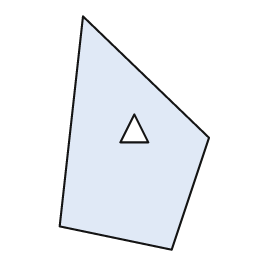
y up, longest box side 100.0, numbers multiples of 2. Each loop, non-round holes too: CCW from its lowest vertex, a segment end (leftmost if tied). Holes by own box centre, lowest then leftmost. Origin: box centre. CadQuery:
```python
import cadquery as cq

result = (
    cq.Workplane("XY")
    .moveTo(16.0, -50.0)
    .lineTo(32.0, -2.0)
    .lineTo(-22.0, 50.0)
    .lineTo(-32.0, -40.0)
    .close()
    .moveTo(-6.0, -4.0)
    .lineTo(6.0, -4.0)
    .lineTo(0.0, 8.0)
    .close()
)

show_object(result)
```